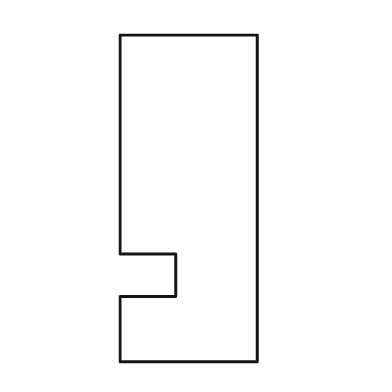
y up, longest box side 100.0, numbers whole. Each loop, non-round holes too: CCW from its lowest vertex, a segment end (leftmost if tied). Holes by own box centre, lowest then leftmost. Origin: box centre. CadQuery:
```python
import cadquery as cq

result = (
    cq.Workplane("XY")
    .moveTo(-21.0, -50.0)
    .lineTo(21.0, -50.0)
    .lineTo(21.0, 50.0)
    .lineTo(-21.0, 50.0)
    .lineTo(-21.0, -17.0)
    .lineTo(-4.0, -17.0)
    .lineTo(-4.0, -30.0)
    .lineTo(-21.0, -30.0)
    .close()
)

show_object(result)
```